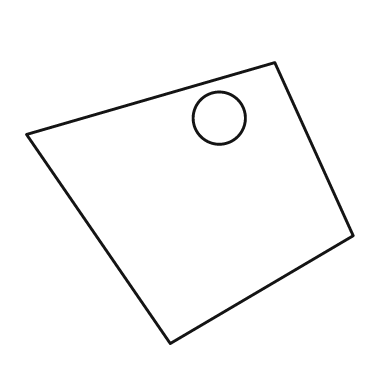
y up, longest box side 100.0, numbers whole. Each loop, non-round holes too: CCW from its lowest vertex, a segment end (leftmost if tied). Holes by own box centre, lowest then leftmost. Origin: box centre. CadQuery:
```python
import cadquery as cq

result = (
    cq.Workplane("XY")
    .moveTo(-6.0, -43.0)
    .lineTo(50.0, -10.0)
    .lineTo(26.0, 43.0)
    .lineTo(-50.0, 21.0)
    .close()
    .moveTo(9.0, 26.0)
    .circle(8.0)
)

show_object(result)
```